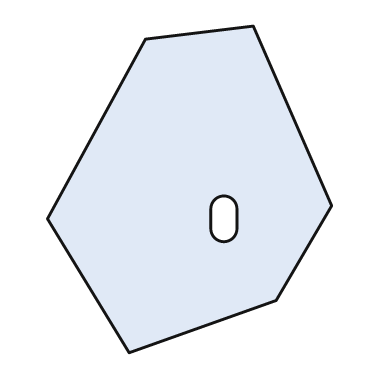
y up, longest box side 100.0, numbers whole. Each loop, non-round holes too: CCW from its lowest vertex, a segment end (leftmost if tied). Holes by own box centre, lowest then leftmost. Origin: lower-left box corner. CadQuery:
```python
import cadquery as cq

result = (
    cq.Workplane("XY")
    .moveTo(25.0, 0.0)
    .lineTo(70.0, 16.0)
    .lineTo(87.0, 45.0)
    .lineTo(63.0, 100.0)
    .lineTo(30.0, 96.0)
    .lineTo(0.0, 41.0)
    .close()
    .moveTo(50.0, 38.0)
    .threePointArc((54.0, 34.0), (58.0, 38.0))
    .lineTo(58.0, 44.0)
    .threePointArc((54.0, 48.0), (50.0, 44.0))
    .close()
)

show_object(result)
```